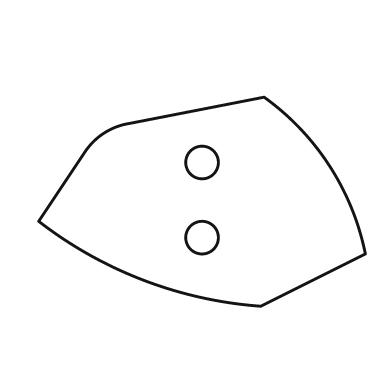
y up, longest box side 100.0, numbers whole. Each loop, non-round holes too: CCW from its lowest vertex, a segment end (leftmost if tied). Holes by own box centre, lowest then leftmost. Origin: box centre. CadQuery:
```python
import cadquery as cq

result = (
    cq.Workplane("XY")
    .moveTo(18.0, -32.0)
    .lineTo(50.0, -16.0)
    .threePointArc((39.0, 11.0), (19.0, 32.0))
    .lineTo(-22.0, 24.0)
    .threePointArc((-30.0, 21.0), (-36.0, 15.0))
    .lineTo(-50.0, -6.0)
    .threePointArc((-18.0, -24.0), (18.0, -32.0))
    .close()
    .moveTo(0.0, -11.0)
    .circle(5.0)
    .moveTo(0.0, 12.0)
    .circle(5.0)
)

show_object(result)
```